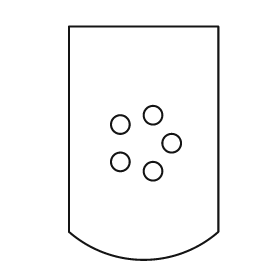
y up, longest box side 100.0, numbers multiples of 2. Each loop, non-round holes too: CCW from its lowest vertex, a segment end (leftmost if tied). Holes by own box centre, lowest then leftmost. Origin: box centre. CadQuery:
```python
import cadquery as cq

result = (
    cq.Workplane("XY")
    .moveTo(-32.0, -38.0)
    .threePointArc((0.0, -50.0), (32.0, -38.0))
    .lineTo(32.0, 50.0)
    .lineTo(-32.0, 50.0)
    .close()
    .moveTo(4.0, -12.0)
    .circle(4.0)
    .moveTo(-10.0, -8.0)
    .circle(4.0)
    .moveTo(12.0, 0.0)
    .circle(4.0)
    .moveTo(-10.0, 8.0)
    .circle(4.0)
    .moveTo(4.0, 12.0)
    .circle(4.0)
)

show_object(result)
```